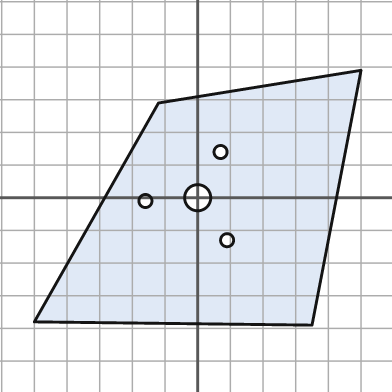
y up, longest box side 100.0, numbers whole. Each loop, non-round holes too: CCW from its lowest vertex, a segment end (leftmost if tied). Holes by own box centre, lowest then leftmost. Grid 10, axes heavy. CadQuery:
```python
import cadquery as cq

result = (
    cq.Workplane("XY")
    .moveTo(35.0, -39.0)
    .lineTo(50.0, 39.0)
    .lineTo(-12.0, 29.0)
    .lineTo(-50.0, -38.0)
    .close()
    .moveTo(9.0, -13.0)
    .circle(2.0)
    .moveTo(-16.0, -1.0)
    .circle(2.0)
    .moveTo(0.0, 0.0)
    .circle(4.0)
    .moveTo(7.0, 14.0)
    .circle(2.0)
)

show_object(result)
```